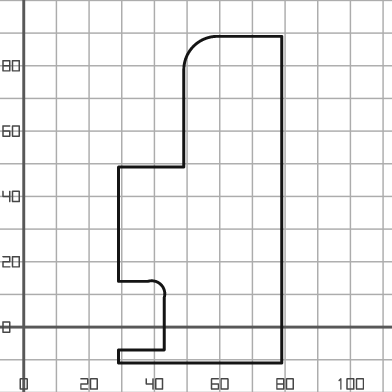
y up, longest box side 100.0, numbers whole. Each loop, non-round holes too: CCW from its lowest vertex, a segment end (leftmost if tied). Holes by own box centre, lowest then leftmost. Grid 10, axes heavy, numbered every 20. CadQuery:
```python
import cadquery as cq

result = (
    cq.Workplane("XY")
    .moveTo(29.0, -11.0)
    .lineTo(79.0, -11.0)
    .lineTo(79.0, 89.0)
    .lineTo(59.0, 89.0)
    .threePointArc((52.0, 86.0), (49.0, 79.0))
    .lineTo(49.0, 49.0)
    .lineTo(29.0, 49.0)
    .lineTo(29.0, 14.0)
    .lineTo(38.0, 14.0)
    .threePointArc((42.0, 13.0), (43.0, 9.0))
    .lineTo(43.0, -7.0)
    .lineTo(29.0, -7.0)
    .close()
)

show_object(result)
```